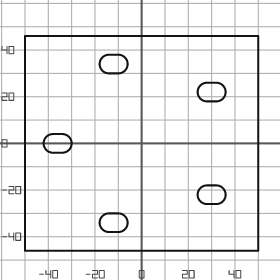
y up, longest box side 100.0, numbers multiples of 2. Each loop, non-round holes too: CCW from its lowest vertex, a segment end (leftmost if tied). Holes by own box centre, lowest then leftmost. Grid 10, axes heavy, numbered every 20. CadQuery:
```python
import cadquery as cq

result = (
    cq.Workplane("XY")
    .moveTo(-50.0, -46.0)
    .lineTo(50.0, -46.0)
    .lineTo(50.0, 46.0)
    .lineTo(-50.0, 46.0)
    .close()
    .moveTo(-14.0, -38.0)
    .lineTo(-10.0, -38.0)
    .threePointArc((-6.0, -34.0), (-10.0, -30.0))
    .lineTo(-14.0, -30.0)
    .threePointArc((-18.0, -34.0), (-14.0, -38.0))
    .close()
    .moveTo(28.0, -26.0)
    .lineTo(32.0, -26.0)
    .threePointArc((36.0, -22.0), (32.0, -18.0))
    .lineTo(28.0, -18.0)
    .threePointArc((24.0, -22.0), (28.0, -26.0))
    .close()
    .moveTo(-38.0, -4.0)
    .lineTo(-34.0, -4.0)
    .threePointArc((-30.0, 0.0), (-34.0, 4.0))
    .lineTo(-38.0, 4.0)
    .threePointArc((-42.0, 0.0), (-38.0, -4.0))
    .close()
    .moveTo(28.0, 18.0)
    .lineTo(32.0, 18.0)
    .threePointArc((36.0, 22.0), (32.0, 26.0))
    .lineTo(28.0, 26.0)
    .threePointArc((24.0, 22.0), (28.0, 18.0))
    .close()
    .moveTo(-14.0, 30.0)
    .lineTo(-10.0, 30.0)
    .threePointArc((-6.0, 34.0), (-10.0, 38.0))
    .lineTo(-14.0, 38.0)
    .threePointArc((-18.0, 34.0), (-14.0, 30.0))
    .close()
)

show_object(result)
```